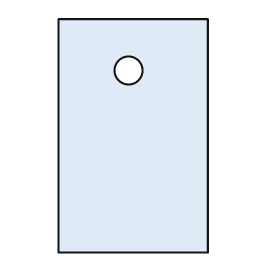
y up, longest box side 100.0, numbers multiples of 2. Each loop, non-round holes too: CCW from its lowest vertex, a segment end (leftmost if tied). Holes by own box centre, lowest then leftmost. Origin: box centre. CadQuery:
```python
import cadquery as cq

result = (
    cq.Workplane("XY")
    .moveTo(-32.0, -50.0)
    .lineTo(32.0, -50.0)
    .lineTo(32.0, 50.0)
    .lineTo(-32.0, 50.0)
    .close()
    .moveTo(-2.0, 28.0)
    .circle(6.0)
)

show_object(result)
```